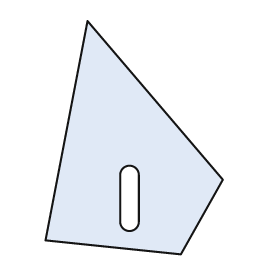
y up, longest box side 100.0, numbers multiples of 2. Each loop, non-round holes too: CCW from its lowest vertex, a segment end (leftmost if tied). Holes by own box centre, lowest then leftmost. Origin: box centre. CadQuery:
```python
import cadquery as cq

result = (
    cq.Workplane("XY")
    .moveTo(20.0, -50.0)
    .lineTo(38.0, -18.0)
    .lineTo(-20.0, 50.0)
    .lineTo(-38.0, -44.0)
    .close()
    .moveTo(-6.0, -36.0)
    .threePointArc((-2.0, -40.0), (2.0, -36.0))
    .lineTo(2.0, -16.0)
    .threePointArc((-2.0, -12.0), (-6.0, -16.0))
    .close()
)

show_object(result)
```